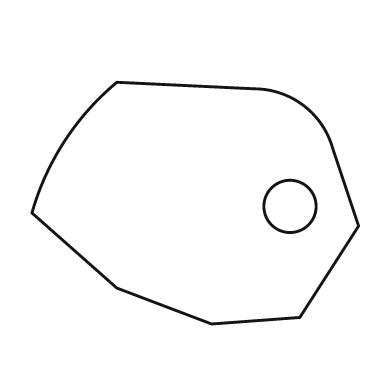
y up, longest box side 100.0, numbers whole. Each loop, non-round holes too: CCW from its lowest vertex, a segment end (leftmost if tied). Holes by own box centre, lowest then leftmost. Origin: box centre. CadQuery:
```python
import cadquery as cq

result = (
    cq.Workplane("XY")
    .moveTo(5.0, -37.0)
    .lineTo(32.0, -35.0)
    .lineTo(50.0, -7.0)
    .lineTo(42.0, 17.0)
    .threePointArc((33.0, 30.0), (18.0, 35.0))
    .lineTo(-24.0, 37.0)
    .threePointArc((-40.0, 19.0), (-50.0, -3.0))
    .lineTo(-24.0, -26.0)
    .close()
    .moveTo(29.0, -1.0)
    .circle(8.0)
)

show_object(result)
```